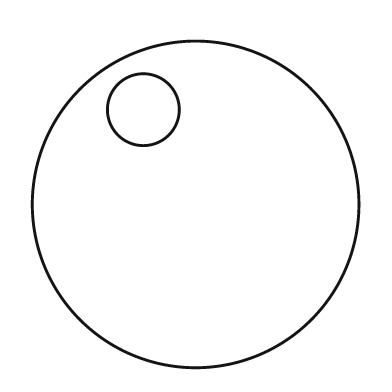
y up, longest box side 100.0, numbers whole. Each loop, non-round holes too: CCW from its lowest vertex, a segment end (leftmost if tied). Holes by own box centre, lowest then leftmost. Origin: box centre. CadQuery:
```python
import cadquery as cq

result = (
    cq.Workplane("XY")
    .moveTo(0.0, 0.0)
    .circle(50.0)
    .moveTo(-16.0, 29.0)
    .circle(11.0)
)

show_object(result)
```